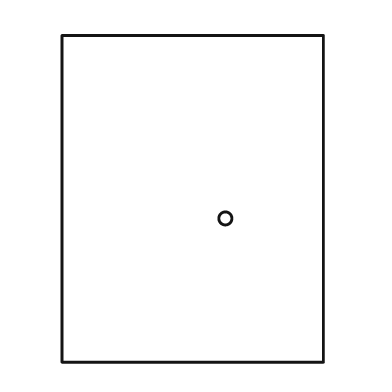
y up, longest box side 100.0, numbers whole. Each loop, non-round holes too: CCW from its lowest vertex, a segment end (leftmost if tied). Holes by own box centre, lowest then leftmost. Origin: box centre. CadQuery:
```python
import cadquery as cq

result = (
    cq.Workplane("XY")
    .moveTo(-40.0, -50.0)
    .lineTo(40.0, -50.0)
    .lineTo(40.0, 50.0)
    .lineTo(-40.0, 50.0)
    .close()
    .moveTo(10.0, -6.0)
    .circle(2.0)
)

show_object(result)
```